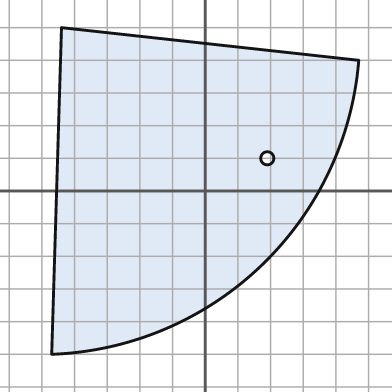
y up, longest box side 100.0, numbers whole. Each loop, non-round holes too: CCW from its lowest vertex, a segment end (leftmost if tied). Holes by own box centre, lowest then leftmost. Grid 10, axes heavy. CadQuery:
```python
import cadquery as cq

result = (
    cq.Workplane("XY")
    .moveTo(-47.0, -50.0)
    .threePointArc((17.0, -23.0), (47.0, 40.0))
    .lineTo(-44.0, 50.0)
    .close()
    .moveTo(19.0, 10.0)
    .circle(2.0)
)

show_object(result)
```